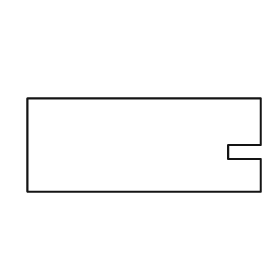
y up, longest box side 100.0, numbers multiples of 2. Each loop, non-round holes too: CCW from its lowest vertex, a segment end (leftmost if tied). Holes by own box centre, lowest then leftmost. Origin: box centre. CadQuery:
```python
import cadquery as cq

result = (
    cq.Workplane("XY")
    .moveTo(-50.0, -20.0)
    .lineTo(50.0, -20.0)
    .lineTo(50.0, -6.0)
    .lineTo(36.0, -6.0)
    .lineTo(36.0, 0.0)
    .lineTo(50.0, 0.0)
    .lineTo(50.0, 20.0)
    .lineTo(-50.0, 20.0)
    .close()
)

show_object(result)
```